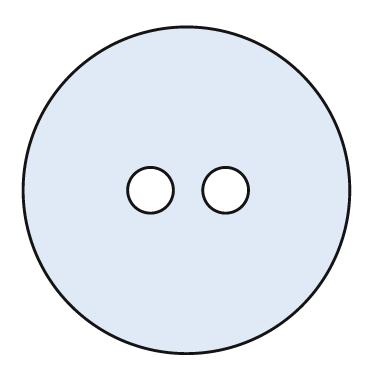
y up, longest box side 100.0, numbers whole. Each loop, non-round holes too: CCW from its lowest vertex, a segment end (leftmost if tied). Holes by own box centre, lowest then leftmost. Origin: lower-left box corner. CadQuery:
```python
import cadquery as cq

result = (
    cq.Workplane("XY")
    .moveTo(50.0, 50.0)
    .circle(50.0)
    .moveTo(39.0, 50.0)
    .circle(7.0)
    .moveTo(62.0, 50.0)
    .circle(7.0)
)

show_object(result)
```